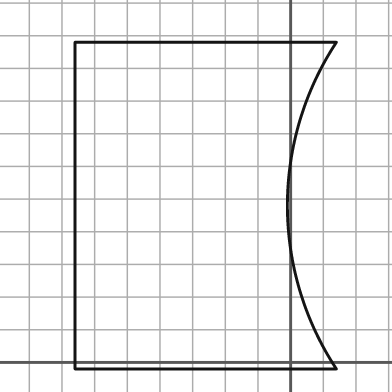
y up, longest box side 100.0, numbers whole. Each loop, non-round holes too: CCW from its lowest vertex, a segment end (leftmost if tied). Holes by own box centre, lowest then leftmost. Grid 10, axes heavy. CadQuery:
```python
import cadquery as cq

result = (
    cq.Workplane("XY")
    .moveTo(-66.0, -2.0)
    .lineTo(14.0, -2.0)
    .threePointArc((-1.0, 48.0), (14.0, 98.0))
    .lineTo(-66.0, 98.0)
    .close()
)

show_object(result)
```